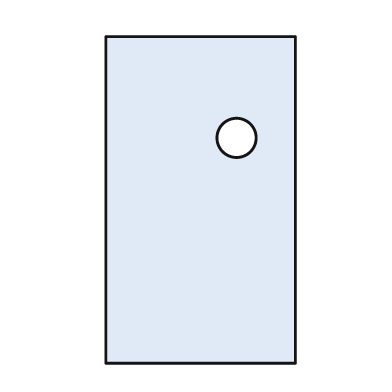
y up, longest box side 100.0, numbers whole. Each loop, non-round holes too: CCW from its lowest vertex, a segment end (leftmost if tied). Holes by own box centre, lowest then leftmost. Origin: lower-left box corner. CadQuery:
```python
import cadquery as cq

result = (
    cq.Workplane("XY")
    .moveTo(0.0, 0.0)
    .lineTo(58.0, 0.0)
    .lineTo(58.0, 100.0)
    .lineTo(0.0, 100.0)
    .close()
    .moveTo(40.0, 69.0)
    .circle(6.0)
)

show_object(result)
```